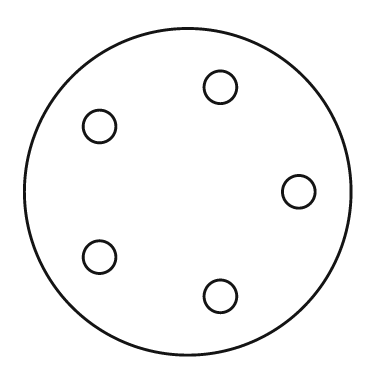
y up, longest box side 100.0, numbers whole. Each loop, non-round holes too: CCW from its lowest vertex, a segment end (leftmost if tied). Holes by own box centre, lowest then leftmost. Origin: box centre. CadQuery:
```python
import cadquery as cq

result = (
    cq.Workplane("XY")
    .moveTo(0.0, 0.0)
    .circle(50.0)
    .moveTo(10.0, -32.0)
    .circle(5.0)
    .moveTo(-27.0, -20.0)
    .circle(5.0)
    .moveTo(34.0, 0.0)
    .circle(5.0)
    .moveTo(-27.0, 20.0)
    .circle(5.0)
    .moveTo(10.0, 32.0)
    .circle(5.0)
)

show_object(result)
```